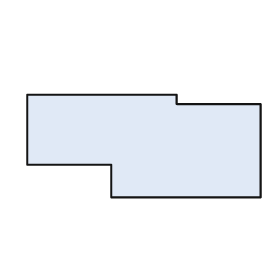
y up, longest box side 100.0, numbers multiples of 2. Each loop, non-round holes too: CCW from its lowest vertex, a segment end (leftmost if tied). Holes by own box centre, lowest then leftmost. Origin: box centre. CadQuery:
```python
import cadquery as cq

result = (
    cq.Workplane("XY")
    .moveTo(-14.0, -22.0)
    .lineTo(50.0, -22.0)
    .lineTo(50.0, 18.0)
    .lineTo(14.0, 18.0)
    .lineTo(14.0, 22.0)
    .lineTo(-50.0, 22.0)
    .lineTo(-50.0, -8.0)
    .lineTo(-14.0, -8.0)
    .close()
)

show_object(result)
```